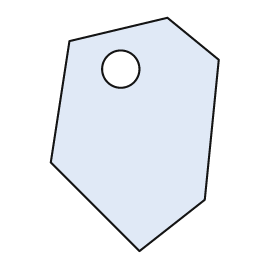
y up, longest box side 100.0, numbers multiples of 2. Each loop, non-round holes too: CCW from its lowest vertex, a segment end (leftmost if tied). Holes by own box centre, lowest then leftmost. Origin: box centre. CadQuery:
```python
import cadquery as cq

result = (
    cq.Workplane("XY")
    .moveTo(2.0, -50.0)
    .lineTo(30.0, -28.0)
    .lineTo(36.0, 32.0)
    .lineTo(14.0, 50.0)
    .lineTo(-28.0, 40.0)
    .lineTo(-36.0, -12.0)
    .close()
    .moveTo(-6.0, 28.0)
    .circle(8.0)
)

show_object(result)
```